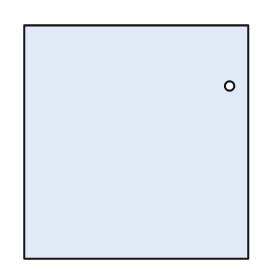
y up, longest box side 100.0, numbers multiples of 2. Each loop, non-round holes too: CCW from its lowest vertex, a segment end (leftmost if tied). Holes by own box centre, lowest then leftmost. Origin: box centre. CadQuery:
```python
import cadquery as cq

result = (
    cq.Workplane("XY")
    .moveTo(-48.0, -50.0)
    .lineTo(48.0, -50.0)
    .lineTo(48.0, 50.0)
    .lineTo(-48.0, 50.0)
    .close()
    .moveTo(40.0, 24.0)
    .circle(2.0)
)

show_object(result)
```